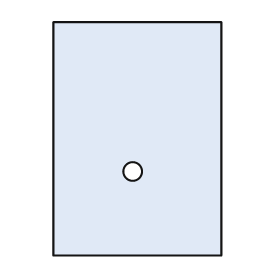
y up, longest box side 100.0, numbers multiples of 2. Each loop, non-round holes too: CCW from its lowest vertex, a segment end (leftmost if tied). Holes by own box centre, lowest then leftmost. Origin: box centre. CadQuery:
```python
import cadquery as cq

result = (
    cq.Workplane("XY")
    .moveTo(-36.0, -50.0)
    .lineTo(36.0, -50.0)
    .lineTo(36.0, 50.0)
    .lineTo(-36.0, 50.0)
    .close()
    .moveTo(-2.0, -14.0)
    .circle(4.0)
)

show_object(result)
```